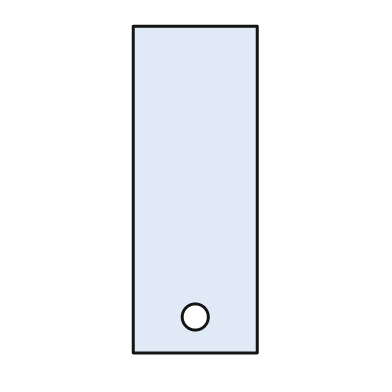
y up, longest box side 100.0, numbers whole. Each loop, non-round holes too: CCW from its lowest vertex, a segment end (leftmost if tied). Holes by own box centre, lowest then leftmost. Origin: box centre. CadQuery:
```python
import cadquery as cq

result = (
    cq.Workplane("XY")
    .moveTo(-19.0, -50.0)
    .lineTo(19.0, -50.0)
    .lineTo(19.0, 50.0)
    .lineTo(-19.0, 50.0)
    .close()
    .moveTo(0.0, -39.0)
    .circle(4.0)
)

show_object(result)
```